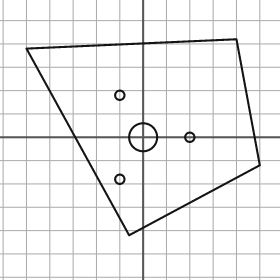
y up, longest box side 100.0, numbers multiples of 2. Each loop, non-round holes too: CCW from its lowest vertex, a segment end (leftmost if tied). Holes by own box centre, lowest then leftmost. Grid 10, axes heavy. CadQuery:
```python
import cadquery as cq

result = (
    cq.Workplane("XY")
    .moveTo(-6.0, -42.0)
    .lineTo(50.0, -12.0)
    .lineTo(40.0, 42.0)
    .lineTo(-50.0, 38.0)
    .close()
    .moveTo(-10.0, -18.0)
    .circle(2.0)
    .moveTo(0.0, 0.0)
    .circle(6.0)
    .moveTo(20.0, 0.0)
    .circle(2.0)
    .moveTo(-10.0, 18.0)
    .circle(2.0)
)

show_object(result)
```